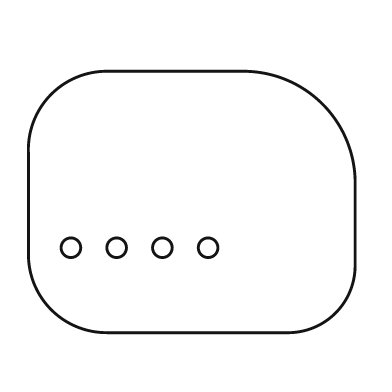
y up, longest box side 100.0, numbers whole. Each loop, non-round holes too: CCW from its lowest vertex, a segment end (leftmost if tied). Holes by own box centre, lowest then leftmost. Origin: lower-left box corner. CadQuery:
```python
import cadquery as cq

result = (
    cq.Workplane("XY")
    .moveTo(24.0, 0.0)
    .lineTo(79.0, 0.0)
    .threePointArc((94.0, 6.0), (100.0, 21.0))
    .lineTo(100.0, 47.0)
    .threePointArc((90.0, 70.0), (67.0, 80.0))
    .lineTo(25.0, 80.0)
    .threePointArc((7.0, 73.0), (0.0, 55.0))
    .lineTo(0.0, 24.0)
    .threePointArc((7.0, 7.0), (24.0, 0.0))
    .close()
    .moveTo(13.0, 26.0)
    .circle(3.0)
    .moveTo(27.0, 26.0)
    .circle(3.0)
    .moveTo(41.0, 26.0)
    .circle(3.0)
    .moveTo(55.0, 26.0)
    .circle(3.0)
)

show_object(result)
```